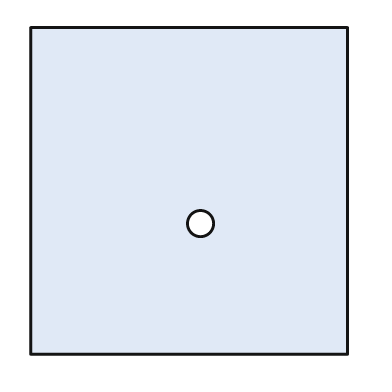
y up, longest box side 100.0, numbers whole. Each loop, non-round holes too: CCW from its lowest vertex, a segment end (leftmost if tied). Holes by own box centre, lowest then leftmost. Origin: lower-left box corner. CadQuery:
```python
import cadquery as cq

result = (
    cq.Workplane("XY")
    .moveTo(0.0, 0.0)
    .lineTo(97.0, 0.0)
    .lineTo(97.0, 100.0)
    .lineTo(0.0, 100.0)
    .close()
    .moveTo(52.0, 40.0)
    .circle(4.0)
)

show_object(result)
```